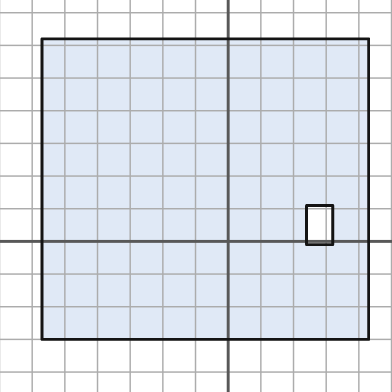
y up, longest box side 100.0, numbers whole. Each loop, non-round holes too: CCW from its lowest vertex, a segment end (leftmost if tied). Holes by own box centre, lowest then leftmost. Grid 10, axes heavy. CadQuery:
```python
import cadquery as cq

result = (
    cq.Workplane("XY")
    .moveTo(-57.0, -30.0)
    .lineTo(43.0, -30.0)
    .lineTo(43.0, 62.0)
    .lineTo(-57.0, 62.0)
    .close()
    .moveTo(24.0, -1.0)
    .lineTo(32.0, -1.0)
    .lineTo(32.0, 11.0)
    .lineTo(24.0, 11.0)
    .close()
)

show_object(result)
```